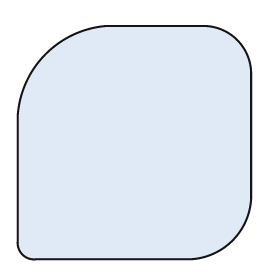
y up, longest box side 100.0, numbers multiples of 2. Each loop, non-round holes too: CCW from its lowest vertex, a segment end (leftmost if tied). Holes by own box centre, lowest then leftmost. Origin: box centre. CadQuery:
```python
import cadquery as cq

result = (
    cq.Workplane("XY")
    .moveTo(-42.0, -50.0)
    .lineTo(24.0, -50.0)
    .threePointArc((42.0, -42.0), (50.0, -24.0))
    .lineTo(50.0, 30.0)
    .threePointArc((44.0, 44.0), (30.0, 50.0))
    .lineTo(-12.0, 50.0)
    .threePointArc((-38.0, 38.0), (-50.0, 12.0))
    .lineTo(-50.0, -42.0)
    .threePointArc((-48.0, -48.0), (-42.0, -50.0))
    .close()
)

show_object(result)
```